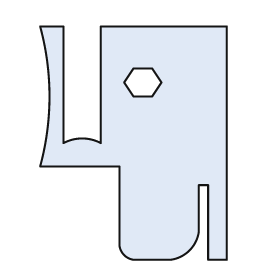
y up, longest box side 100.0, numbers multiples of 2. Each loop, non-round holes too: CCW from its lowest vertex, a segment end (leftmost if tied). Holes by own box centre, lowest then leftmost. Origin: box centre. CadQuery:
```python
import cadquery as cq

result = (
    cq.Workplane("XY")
    .moveTo(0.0, -50.0)
    .lineTo(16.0, -50.0)
    .threePointArc((24.0, -46.0), (28.0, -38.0))
    .lineTo(28.0, -18.0)
    .lineTo(32.0, -18.0)
    .lineTo(32.0, -50.0)
    .lineTo(40.0, -50.0)
    .lineTo(40.0, 50.0)
    .lineTo(-14.0, 50.0)
    .lineTo(-14.0, 0.0)
    .threePointArc((-22.0, 2.0), (-30.0, 0.0))
    .lineTo(-30.0, 50.0)
    .lineTo(-40.0, 50.0)
    .threePointArc((-36.0, 20.0), (-40.0, -10.0))
    .lineTo(-6.0, -10.0)
    .lineTo(-6.0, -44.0)
    .threePointArc((-4.0, -48.0), (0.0, -50.0))
    .close()
    .moveTo(0.0, 20.0)
    .lineTo(8.0, 20.0)
    .lineTo(12.0, 26.0)
    .lineTo(8.0, 32.0)
    .lineTo(0.0, 32.0)
    .lineTo(-4.0, 26.0)
    .close()
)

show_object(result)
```